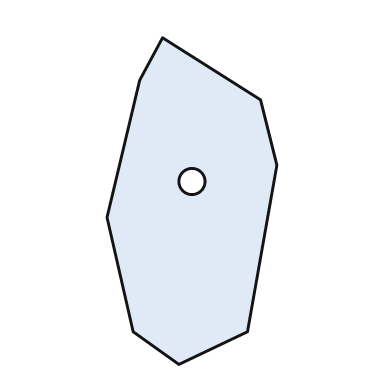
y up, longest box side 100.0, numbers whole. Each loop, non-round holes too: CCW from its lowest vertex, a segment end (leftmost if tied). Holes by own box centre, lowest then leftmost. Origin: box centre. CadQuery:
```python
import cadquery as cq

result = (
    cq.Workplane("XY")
    .moveTo(-4.0, -50.0)
    .lineTo(17.0, -40.0)
    .lineTo(26.0, 11.0)
    .lineTo(21.0, 31.0)
    .lineTo(-9.0, 50.0)
    .lineTo(-16.0, 37.0)
    .lineTo(-26.0, -5.0)
    .lineTo(-18.0, -40.0)
    .close()
    .moveTo(0.0, 6.0)
    .circle(4.0)
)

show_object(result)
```